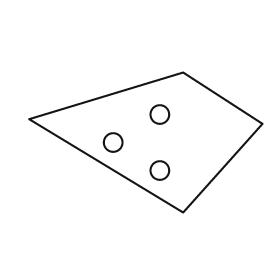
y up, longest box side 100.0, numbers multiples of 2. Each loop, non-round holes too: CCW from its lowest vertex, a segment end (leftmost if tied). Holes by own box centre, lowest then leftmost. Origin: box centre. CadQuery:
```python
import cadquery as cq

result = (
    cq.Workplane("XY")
    .moveTo(16.0, -30.0)
    .lineTo(50.0, 8.0)
    .lineTo(16.0, 30.0)
    .lineTo(-50.0, 10.0)
    .close()
    .moveTo(6.0, -12.0)
    .circle(4.0)
    .moveTo(-14.0, 0.0)
    .circle(4.0)
    .moveTo(6.0, 12.0)
    .circle(4.0)
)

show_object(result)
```